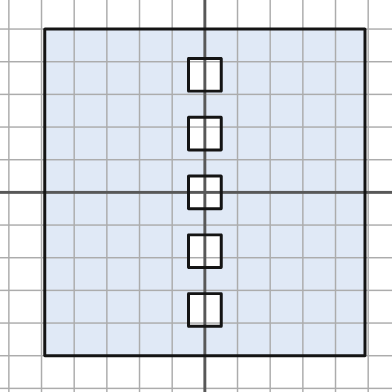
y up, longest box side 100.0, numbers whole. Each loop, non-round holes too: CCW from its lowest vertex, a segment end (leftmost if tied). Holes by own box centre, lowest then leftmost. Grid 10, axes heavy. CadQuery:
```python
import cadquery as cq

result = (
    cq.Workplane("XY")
    .moveTo(-49.0, -50.0)
    .lineTo(49.0, -50.0)
    .lineTo(49.0, 50.0)
    .lineTo(-49.0, 50.0)
    .close()
    .moveTo(-5.0, -41.0)
    .lineTo(5.0, -41.0)
    .lineTo(5.0, -31.0)
    .lineTo(-5.0, -31.0)
    .close()
    .moveTo(-5.0, -23.0)
    .lineTo(5.0, -23.0)
    .lineTo(5.0, -13.0)
    .lineTo(-5.0, -13.0)
    .close()
    .moveTo(-5.0, -5.0)
    .lineTo(5.0, -5.0)
    .lineTo(5.0, 5.0)
    .lineTo(-5.0, 5.0)
    .close()
    .moveTo(-5.0, 13.0)
    .lineTo(5.0, 13.0)
    .lineTo(5.0, 23.0)
    .lineTo(-5.0, 23.0)
    .close()
    .moveTo(-5.0, 31.0)
    .lineTo(5.0, 31.0)
    .lineTo(5.0, 41.0)
    .lineTo(-5.0, 41.0)
    .close()
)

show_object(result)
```